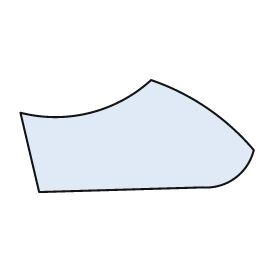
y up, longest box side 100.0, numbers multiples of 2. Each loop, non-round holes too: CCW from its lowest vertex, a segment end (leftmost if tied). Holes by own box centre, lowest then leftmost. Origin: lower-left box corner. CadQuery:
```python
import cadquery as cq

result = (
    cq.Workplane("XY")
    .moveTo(8.0, 0.0)
    .lineTo(78.0, 2.0)
    .threePointArc((92.0, 6.0), (100.0, 18.0))
    .threePointArc((80.0, 36.0), (56.0, 48.0))
    .threePointArc((30.0, 34.0), (0.0, 34.0))
    .close()
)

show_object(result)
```